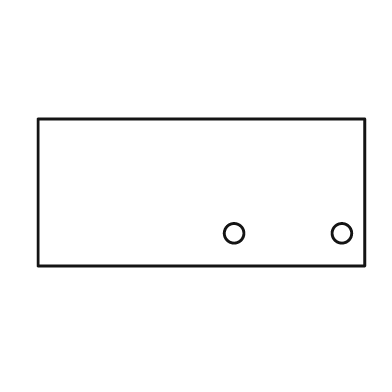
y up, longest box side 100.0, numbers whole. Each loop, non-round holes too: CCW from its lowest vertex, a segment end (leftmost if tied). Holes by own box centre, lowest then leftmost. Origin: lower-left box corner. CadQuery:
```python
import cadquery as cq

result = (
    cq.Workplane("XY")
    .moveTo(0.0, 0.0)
    .lineTo(100.0, 0.0)
    .lineTo(100.0, 45.0)
    .lineTo(0.0, 45.0)
    .close()
    .moveTo(60.0, 10.0)
    .circle(3.0)
    .moveTo(93.0, 10.0)
    .circle(3.0)
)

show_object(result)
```